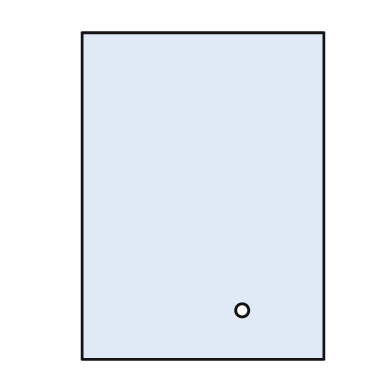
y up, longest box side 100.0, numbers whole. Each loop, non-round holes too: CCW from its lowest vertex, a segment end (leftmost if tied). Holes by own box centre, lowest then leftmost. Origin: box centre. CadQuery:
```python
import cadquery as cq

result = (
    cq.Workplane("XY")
    .moveTo(-37.0, -50.0)
    .lineTo(37.0, -50.0)
    .lineTo(37.0, 50.0)
    .lineTo(-37.0, 50.0)
    .close()
    .moveTo(12.0, -35.0)
    .circle(2.0)
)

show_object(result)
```